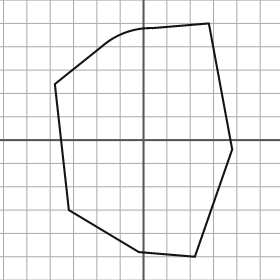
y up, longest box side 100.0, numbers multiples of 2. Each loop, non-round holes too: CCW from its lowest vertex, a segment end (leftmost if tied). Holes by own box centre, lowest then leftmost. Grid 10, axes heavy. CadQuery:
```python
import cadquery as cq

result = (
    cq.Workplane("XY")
    .moveTo(22.0, -50.0)
    .lineTo(38.0, -4.0)
    .lineTo(28.0, 50.0)
    .lineTo(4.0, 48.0)
    .threePointArc((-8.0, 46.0), (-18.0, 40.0))
    .lineTo(-38.0, 24.0)
    .lineTo(-32.0, -30.0)
    .lineTo(-2.0, -48.0)
    .close()
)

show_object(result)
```